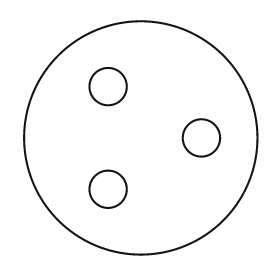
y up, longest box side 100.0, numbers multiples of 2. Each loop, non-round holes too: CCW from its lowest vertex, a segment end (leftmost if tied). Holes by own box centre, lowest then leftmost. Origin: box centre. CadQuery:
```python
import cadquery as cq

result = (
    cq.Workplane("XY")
    .moveTo(0.0, 0.0)
    .circle(50.0)
    .moveTo(-14.0, -22.0)
    .circle(8.0)
    .moveTo(26.0, 0.0)
    .circle(8.0)
    .moveTo(-14.0, 22.0)
    .circle(8.0)
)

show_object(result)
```